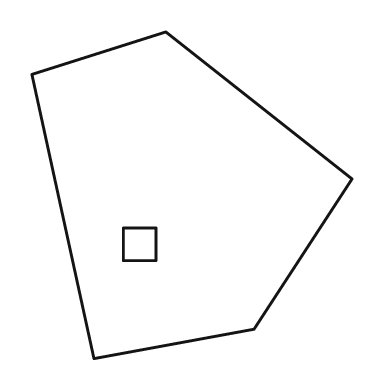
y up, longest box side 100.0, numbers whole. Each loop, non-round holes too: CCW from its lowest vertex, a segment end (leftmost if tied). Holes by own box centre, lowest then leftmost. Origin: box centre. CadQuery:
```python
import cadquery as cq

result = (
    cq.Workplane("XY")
    .moveTo(-30.0, -50.0)
    .lineTo(19.0, -41.0)
    .lineTo(49.0, 5.0)
    .lineTo(-8.0, 50.0)
    .lineTo(-49.0, 37.0)
    .close()
    .moveTo(-21.0, -20.0)
    .lineTo(-11.0, -20.0)
    .lineTo(-11.0, -10.0)
    .lineTo(-21.0, -10.0)
    .close()
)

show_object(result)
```